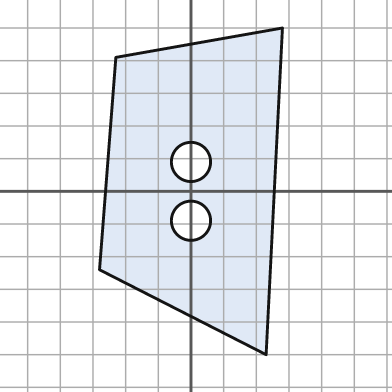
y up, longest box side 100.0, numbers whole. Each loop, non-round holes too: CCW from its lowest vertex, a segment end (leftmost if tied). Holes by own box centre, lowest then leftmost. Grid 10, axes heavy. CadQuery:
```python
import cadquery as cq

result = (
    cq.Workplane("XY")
    .moveTo(23.0, -50.0)
    .lineTo(28.0, 50.0)
    .lineTo(-23.0, 41.0)
    .lineTo(-28.0, -24.0)
    .close()
    .moveTo(0.0, -9.0)
    .circle(6.0)
    .moveTo(0.0, 9.0)
    .circle(6.0)
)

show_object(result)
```